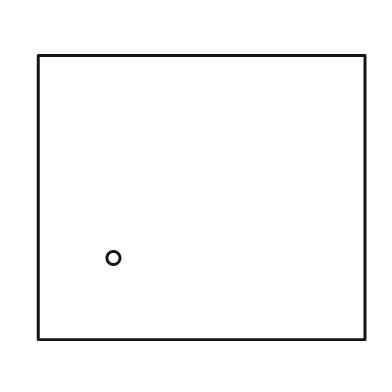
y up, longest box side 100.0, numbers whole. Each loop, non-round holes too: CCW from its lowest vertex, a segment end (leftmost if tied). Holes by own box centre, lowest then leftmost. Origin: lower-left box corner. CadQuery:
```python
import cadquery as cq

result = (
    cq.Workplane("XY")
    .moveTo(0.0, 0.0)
    .lineTo(100.0, 0.0)
    .lineTo(100.0, 87.0)
    .lineTo(0.0, 87.0)
    .close()
    .moveTo(23.0, 25.0)
    .circle(2.0)
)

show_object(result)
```